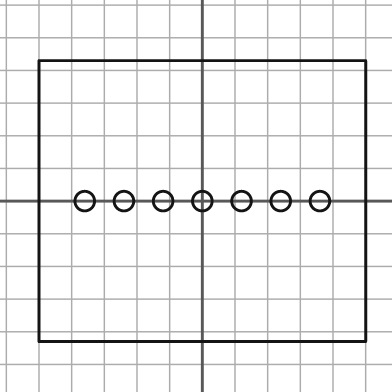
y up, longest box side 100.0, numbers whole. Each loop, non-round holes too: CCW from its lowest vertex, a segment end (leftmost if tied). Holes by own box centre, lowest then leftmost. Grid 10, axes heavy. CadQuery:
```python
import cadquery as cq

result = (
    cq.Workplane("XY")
    .moveTo(-50.0, -43.0)
    .lineTo(50.0, -43.0)
    .lineTo(50.0, 43.0)
    .lineTo(-50.0, 43.0)
    .close()
    .moveTo(-36.0, 0.0)
    .circle(3.0)
    .moveTo(-24.0, 0.0)
    .circle(3.0)
    .moveTo(-12.0, 0.0)
    .circle(3.0)
    .moveTo(0.0, 0.0)
    .circle(3.0)
    .moveTo(12.0, 0.0)
    .circle(3.0)
    .moveTo(24.0, 0.0)
    .circle(3.0)
    .moveTo(36.0, 0.0)
    .circle(3.0)
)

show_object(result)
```